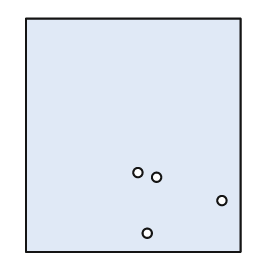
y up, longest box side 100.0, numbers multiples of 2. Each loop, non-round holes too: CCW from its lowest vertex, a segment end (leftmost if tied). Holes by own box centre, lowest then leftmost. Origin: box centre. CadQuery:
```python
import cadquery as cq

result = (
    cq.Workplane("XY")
    .moveTo(-46.0, -50.0)
    .lineTo(46.0, -50.0)
    .lineTo(46.0, 50.0)
    .lineTo(-46.0, 50.0)
    .close()
    .moveTo(6.0, -42.0)
    .circle(2.0)
    .moveTo(38.0, -28.0)
    .circle(2.0)
    .moveTo(10.0, -18.0)
    .circle(2.0)
    .moveTo(2.0, -16.0)
    .circle(2.0)
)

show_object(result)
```